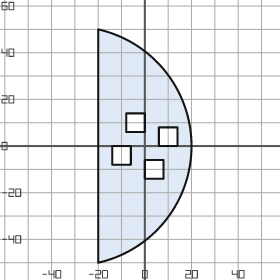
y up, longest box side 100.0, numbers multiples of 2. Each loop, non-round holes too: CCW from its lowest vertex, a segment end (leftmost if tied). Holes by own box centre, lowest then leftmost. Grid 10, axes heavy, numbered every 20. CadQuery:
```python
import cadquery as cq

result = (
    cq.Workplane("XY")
    .moveTo(-20.0, -50.0)
    .threePointArc((20.0, 0.0), (-20.0, 50.0))
    .close()
    .moveTo(0.0, -14.0)
    .lineTo(8.0, -14.0)
    .lineTo(8.0, -6.0)
    .lineTo(0.0, -6.0)
    .close()
    .moveTo(-14.0, -8.0)
    .lineTo(-6.0, -8.0)
    .lineTo(-6.0, 0.0)
    .lineTo(-14.0, 0.0)
    .close()
    .moveTo(6.0, 0.0)
    .lineTo(14.0, 0.0)
    .lineTo(14.0, 8.0)
    .lineTo(6.0, 8.0)
    .close()
    .moveTo(-8.0, 6.0)
    .lineTo(0.0, 6.0)
    .lineTo(0.0, 14.0)
    .lineTo(-8.0, 14.0)
    .close()
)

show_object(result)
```